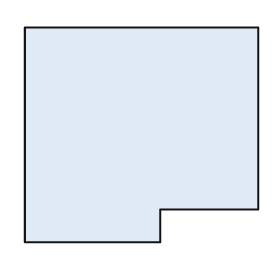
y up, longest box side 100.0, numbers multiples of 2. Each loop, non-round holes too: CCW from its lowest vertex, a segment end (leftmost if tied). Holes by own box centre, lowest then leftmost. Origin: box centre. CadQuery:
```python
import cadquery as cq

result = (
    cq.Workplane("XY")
    .moveTo(-50.0, -46.0)
    .lineTo(8.0, -46.0)
    .lineTo(8.0, -32.0)
    .lineTo(50.0, -32.0)
    .lineTo(50.0, 46.0)
    .lineTo(-50.0, 46.0)
    .close()
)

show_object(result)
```